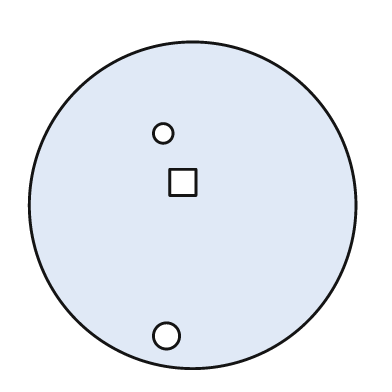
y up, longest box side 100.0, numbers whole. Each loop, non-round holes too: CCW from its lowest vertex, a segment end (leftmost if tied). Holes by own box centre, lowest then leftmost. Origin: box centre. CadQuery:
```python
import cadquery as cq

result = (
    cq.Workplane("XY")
    .moveTo(0.0, 0.0)
    .circle(50.0)
    .moveTo(-8.0, -40.0)
    .circle(4.0)
    .moveTo(-7.0, 3.0)
    .lineTo(1.0, 3.0)
    .lineTo(1.0, 11.0)
    .lineTo(-7.0, 11.0)
    .close()
    .moveTo(-9.0, 22.0)
    .circle(3.0)
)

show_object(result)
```